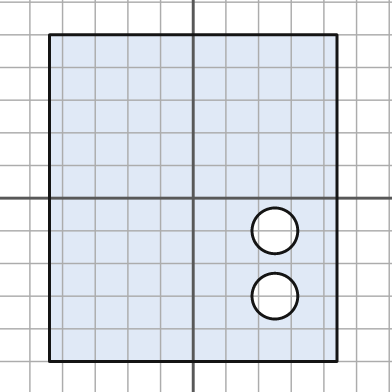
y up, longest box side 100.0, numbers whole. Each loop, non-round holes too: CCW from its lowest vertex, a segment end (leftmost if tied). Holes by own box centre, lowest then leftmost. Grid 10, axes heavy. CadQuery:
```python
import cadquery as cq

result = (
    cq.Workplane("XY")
    .moveTo(-44.0, -50.0)
    .lineTo(44.0, -50.0)
    .lineTo(44.0, 50.0)
    .lineTo(-44.0, 50.0)
    .close()
    .moveTo(25.0, -30.0)
    .circle(7.0)
    .moveTo(25.0, -10.0)
    .circle(7.0)
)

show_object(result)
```